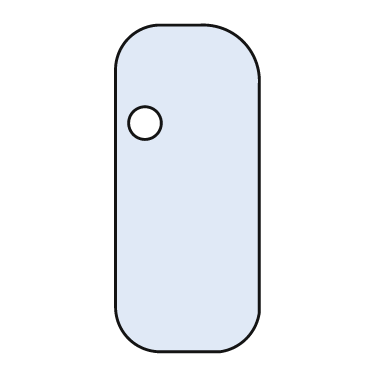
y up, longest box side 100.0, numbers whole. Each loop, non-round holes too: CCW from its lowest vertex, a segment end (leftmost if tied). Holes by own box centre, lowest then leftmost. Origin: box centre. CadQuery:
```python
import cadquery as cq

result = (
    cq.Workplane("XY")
    .moveTo(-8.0, -50.0)
    .lineTo(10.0, -50.0)
    .threePointArc((18.0, -46.0), (22.0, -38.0))
    .lineTo(22.0, 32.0)
    .threePointArc((17.0, 45.0), (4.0, 50.0))
    .lineTo(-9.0, 50.0)
    .threePointArc((-18.0, 46.0), (-22.0, 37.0))
    .lineTo(-22.0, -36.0)
    .threePointArc((-18.0, -46.0), (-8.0, -50.0))
    .close()
    .moveTo(-13.0, 20.0)
    .circle(5.0)
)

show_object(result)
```